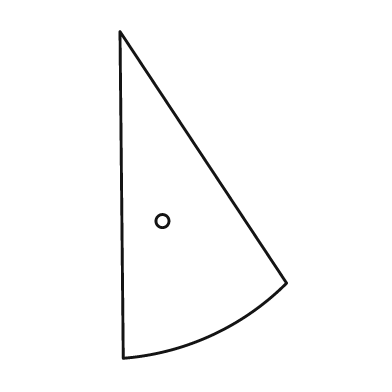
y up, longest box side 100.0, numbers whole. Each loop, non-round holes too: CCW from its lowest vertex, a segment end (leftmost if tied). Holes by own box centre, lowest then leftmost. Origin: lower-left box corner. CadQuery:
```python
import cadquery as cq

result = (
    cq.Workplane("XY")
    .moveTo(1.0, 0.0)
    .threePointArc((28.0, 7.0), (51.0, 23.0))
    .lineTo(0.0, 100.0)
    .close()
    .moveTo(13.0, 42.0)
    .circle(2.0)
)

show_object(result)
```